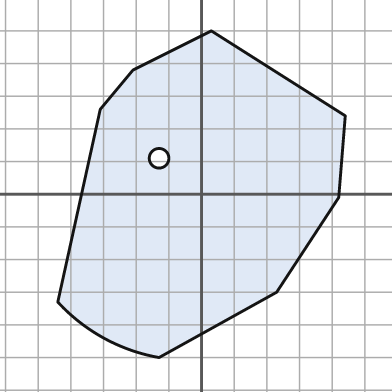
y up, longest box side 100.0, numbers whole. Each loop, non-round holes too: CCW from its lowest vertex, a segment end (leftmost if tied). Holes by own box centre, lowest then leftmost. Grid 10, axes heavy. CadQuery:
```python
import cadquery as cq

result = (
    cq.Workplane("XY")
    .moveTo(-13.0, -50.0)
    .lineTo(23.0, -30.0)
    .lineTo(42.0, -1.0)
    .lineTo(44.0, 24.0)
    .lineTo(3.0, 50.0)
    .lineTo(-21.0, 38.0)
    .lineTo(-31.0, 26.0)
    .lineTo(-44.0, -33.0)
    .threePointArc((-30.0, -44.0), (-13.0, -50.0))
    .close()
    .moveTo(-13.0, 11.0)
    .circle(3.0)
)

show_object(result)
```